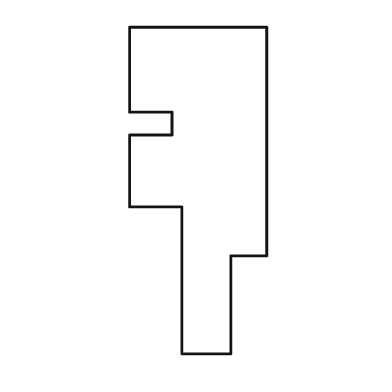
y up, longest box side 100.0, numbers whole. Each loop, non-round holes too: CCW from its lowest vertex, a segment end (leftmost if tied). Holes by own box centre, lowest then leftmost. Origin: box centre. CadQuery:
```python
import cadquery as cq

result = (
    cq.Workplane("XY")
    .moveTo(-5.0, -50.0)
    .lineTo(10.0, -50.0)
    .lineTo(10.0, -20.0)
    .lineTo(21.0, -20.0)
    .lineTo(21.0, 50.0)
    .lineTo(-21.0, 50.0)
    .lineTo(-21.0, 24.0)
    .lineTo(-8.0, 24.0)
    .lineTo(-8.0, 17.0)
    .lineTo(-21.0, 17.0)
    .lineTo(-21.0, -5.0)
    .lineTo(-5.0, -5.0)
    .close()
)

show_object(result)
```